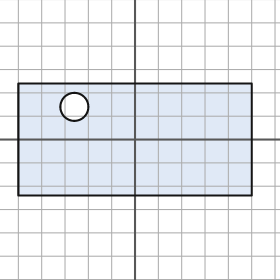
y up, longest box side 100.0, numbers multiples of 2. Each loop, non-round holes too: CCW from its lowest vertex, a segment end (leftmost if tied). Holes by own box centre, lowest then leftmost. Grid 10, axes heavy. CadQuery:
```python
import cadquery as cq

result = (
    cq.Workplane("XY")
    .moveTo(-50.0, -24.0)
    .lineTo(50.0, -24.0)
    .lineTo(50.0, 24.0)
    .lineTo(-50.0, 24.0)
    .close()
    .moveTo(-26.0, 14.0)
    .circle(6.0)
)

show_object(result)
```